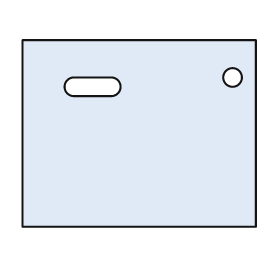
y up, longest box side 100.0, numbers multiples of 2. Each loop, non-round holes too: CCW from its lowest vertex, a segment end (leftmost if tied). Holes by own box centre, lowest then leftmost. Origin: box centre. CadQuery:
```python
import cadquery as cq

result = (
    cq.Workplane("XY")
    .moveTo(-50.0, -40.0)
    .lineTo(50.0, -40.0)
    .lineTo(50.0, 40.0)
    .lineTo(-50.0, 40.0)
    .close()
    .moveTo(-28.0, 16.0)
    .lineTo(-12.0, 16.0)
    .threePointArc((-8.0, 20.0), (-12.0, 24.0))
    .lineTo(-28.0, 24.0)
    .threePointArc((-32.0, 20.0), (-28.0, 16.0))
    .close()
    .moveTo(40.0, 24.0)
    .circle(4.0)
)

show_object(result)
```